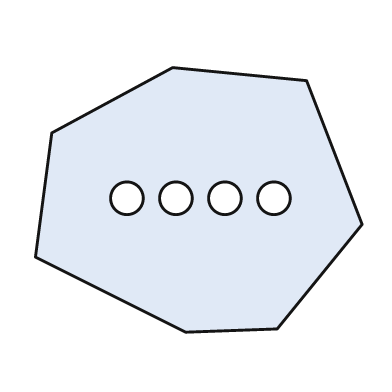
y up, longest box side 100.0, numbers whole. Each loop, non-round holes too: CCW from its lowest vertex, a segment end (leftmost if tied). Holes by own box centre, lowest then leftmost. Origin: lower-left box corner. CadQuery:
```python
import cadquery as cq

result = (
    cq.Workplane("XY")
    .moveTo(46.0, 0.0)
    .lineTo(74.0, 1.0)
    .lineTo(100.0, 33.0)
    .lineTo(83.0, 77.0)
    .lineTo(42.0, 81.0)
    .lineTo(5.0, 61.0)
    .lineTo(0.0, 23.0)
    .close()
    .moveTo(28.0, 41.0)
    .circle(5.0)
    .moveTo(43.0, 41.0)
    .circle(5.0)
    .moveTo(58.0, 41.0)
    .circle(5.0)
    .moveTo(73.0, 41.0)
    .circle(5.0)
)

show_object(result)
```